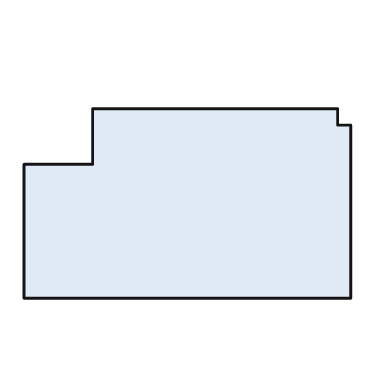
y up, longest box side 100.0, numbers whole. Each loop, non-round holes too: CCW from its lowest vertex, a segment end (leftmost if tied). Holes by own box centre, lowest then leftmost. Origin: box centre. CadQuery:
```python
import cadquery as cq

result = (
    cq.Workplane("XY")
    .moveTo(-50.0, -29.0)
    .lineTo(50.0, -29.0)
    .lineTo(50.0, 24.0)
    .lineTo(46.0, 24.0)
    .lineTo(46.0, 29.0)
    .lineTo(-29.0, 29.0)
    .lineTo(-29.0, 12.0)
    .lineTo(-50.0, 12.0)
    .close()
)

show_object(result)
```